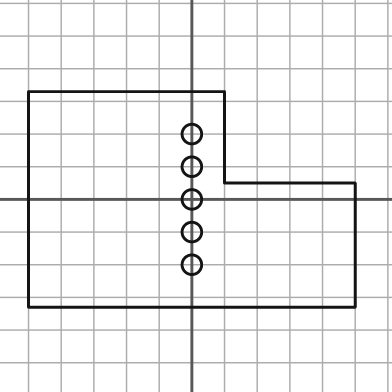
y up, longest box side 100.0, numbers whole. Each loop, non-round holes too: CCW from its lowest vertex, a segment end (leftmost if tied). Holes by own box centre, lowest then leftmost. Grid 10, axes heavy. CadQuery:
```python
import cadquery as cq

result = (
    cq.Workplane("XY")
    .moveTo(-50.0, -33.0)
    .lineTo(50.0, -33.0)
    .lineTo(50.0, 5.0)
    .lineTo(10.0, 5.0)
    .lineTo(10.0, 33.0)
    .lineTo(-50.0, 33.0)
    .close()
    .moveTo(0.0, -20.0)
    .circle(3.0)
    .moveTo(0.0, -10.0)
    .circle(3.0)
    .moveTo(0.0, 0.0)
    .circle(3.0)
    .moveTo(0.0, 10.0)
    .circle(3.0)
    .moveTo(0.0, 20.0)
    .circle(3.0)
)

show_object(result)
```